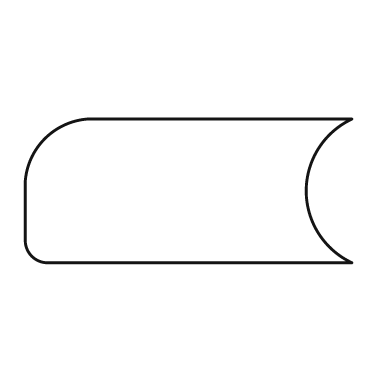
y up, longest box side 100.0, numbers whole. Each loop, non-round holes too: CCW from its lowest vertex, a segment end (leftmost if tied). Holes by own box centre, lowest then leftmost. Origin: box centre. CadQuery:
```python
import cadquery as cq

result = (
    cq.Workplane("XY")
    .moveTo(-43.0, -22.0)
    .lineTo(50.0, -22.0)
    .threePointArc((36.0, 0.0), (50.0, 22.0))
    .lineTo(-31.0, 22.0)
    .threePointArc((-44.0, 16.0), (-50.0, 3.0))
    .lineTo(-50.0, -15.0)
    .threePointArc((-48.0, -20.0), (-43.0, -22.0))
    .close()
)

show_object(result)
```